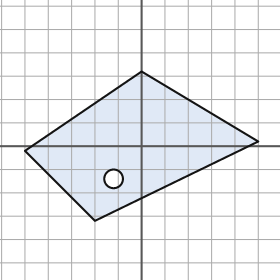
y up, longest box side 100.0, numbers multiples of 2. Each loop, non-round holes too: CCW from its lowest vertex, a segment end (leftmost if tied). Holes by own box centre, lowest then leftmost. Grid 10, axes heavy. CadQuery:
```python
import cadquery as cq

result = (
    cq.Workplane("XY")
    .moveTo(-20.0, -32.0)
    .lineTo(50.0, 2.0)
    .lineTo(0.0, 32.0)
    .lineTo(-50.0, -2.0)
    .close()
    .moveTo(-12.0, -14.0)
    .circle(4.0)
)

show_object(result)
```